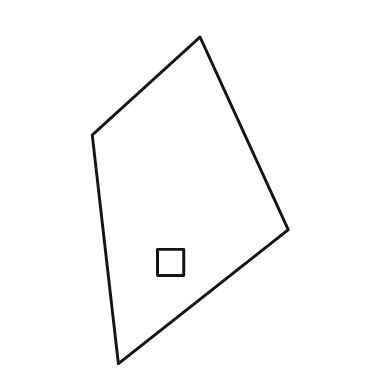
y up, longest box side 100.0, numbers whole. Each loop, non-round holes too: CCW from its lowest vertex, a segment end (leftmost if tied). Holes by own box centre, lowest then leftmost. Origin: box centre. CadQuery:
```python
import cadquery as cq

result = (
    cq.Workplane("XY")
    .moveTo(-22.0, -50.0)
    .lineTo(30.0, -9.0)
    .lineTo(3.0, 50.0)
    .lineTo(-30.0, 20.0)
    .close()
    .moveTo(-10.0, -23.0)
    .lineTo(-2.0, -23.0)
    .lineTo(-2.0, -15.0)
    .lineTo(-10.0, -15.0)
    .close()
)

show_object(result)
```